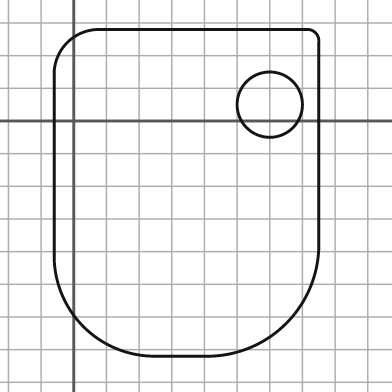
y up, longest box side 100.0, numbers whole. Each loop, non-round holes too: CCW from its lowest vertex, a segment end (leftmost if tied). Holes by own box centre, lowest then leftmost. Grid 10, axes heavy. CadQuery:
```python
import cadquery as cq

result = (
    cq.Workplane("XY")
    .moveTo(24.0, -72.0)
    .lineTo(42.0, -72.0)
    .threePointArc((65.0, -62.0), (75.0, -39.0))
    .lineTo(75.0, 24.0)
    .threePointArc((74.0, 27.0), (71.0, 28.0))
    .lineTo(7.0, 28.0)
    .threePointArc((-2.0, 24.0), (-6.0, 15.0))
    .lineTo(-6.0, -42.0)
    .threePointArc((3.0, -63.0), (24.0, -72.0))
    .close()
    .moveTo(60.0, 5.0)
    .circle(10.0)
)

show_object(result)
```